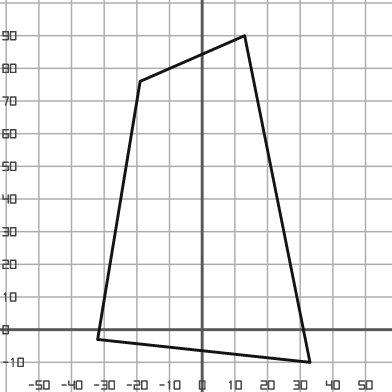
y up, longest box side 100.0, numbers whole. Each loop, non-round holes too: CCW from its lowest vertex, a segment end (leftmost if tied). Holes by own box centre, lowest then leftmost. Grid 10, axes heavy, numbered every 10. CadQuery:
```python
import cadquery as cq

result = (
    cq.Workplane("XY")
    .moveTo(33.0, -10.0)
    .lineTo(13.0, 90.0)
    .lineTo(-19.0, 76.0)
    .lineTo(-32.0, -3.0)
    .close()
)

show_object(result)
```